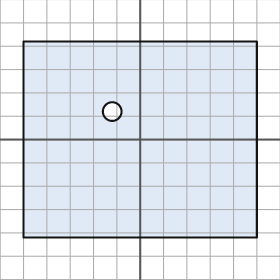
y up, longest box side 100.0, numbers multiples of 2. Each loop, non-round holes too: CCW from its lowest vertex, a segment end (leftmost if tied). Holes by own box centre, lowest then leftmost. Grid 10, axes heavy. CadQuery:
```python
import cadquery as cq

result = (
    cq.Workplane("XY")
    .moveTo(-50.0, -42.0)
    .lineTo(50.0, -42.0)
    .lineTo(50.0, 42.0)
    .lineTo(-50.0, 42.0)
    .close()
    .moveTo(-12.0, 12.0)
    .circle(4.0)
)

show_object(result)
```